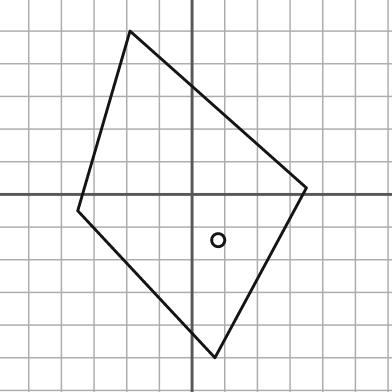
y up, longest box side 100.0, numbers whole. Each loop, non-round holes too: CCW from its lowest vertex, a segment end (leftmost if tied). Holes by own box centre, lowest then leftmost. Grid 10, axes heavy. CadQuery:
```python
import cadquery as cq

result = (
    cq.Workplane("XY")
    .moveTo(7.0, -50.0)
    .lineTo(35.0, 2.0)
    .lineTo(-19.0, 50.0)
    .lineTo(-35.0, -5.0)
    .close()
    .moveTo(8.0, -14.0)
    .circle(2.0)
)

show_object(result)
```